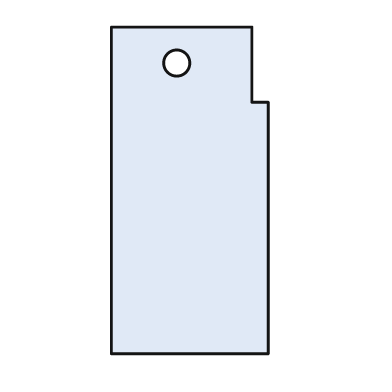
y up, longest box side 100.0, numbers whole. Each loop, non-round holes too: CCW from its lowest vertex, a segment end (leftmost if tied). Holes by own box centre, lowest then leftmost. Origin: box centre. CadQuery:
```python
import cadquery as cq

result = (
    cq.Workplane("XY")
    .moveTo(-24.0, -50.0)
    .lineTo(24.0, -50.0)
    .lineTo(24.0, 27.0)
    .lineTo(19.0, 27.0)
    .lineTo(19.0, 50.0)
    .lineTo(-24.0, 50.0)
    .close()
    .moveTo(-4.0, 39.0)
    .circle(4.0)
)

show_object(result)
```